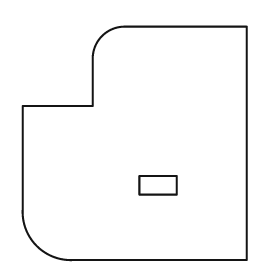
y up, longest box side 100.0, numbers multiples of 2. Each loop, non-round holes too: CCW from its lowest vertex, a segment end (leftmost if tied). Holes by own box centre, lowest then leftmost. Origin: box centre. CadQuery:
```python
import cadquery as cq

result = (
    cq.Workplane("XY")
    .moveTo(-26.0, -50.0)
    .lineTo(48.0, -50.0)
    .lineTo(48.0, 50.0)
    .lineTo(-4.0, 50.0)
    .threePointArc((-14.0, 46.0), (-18.0, 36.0))
    .lineTo(-18.0, 16.0)
    .lineTo(-48.0, 16.0)
    .lineTo(-48.0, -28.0)
    .threePointArc((-42.0, -44.0), (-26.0, -50.0))
    .close()
    .moveTo(2.0, -22.0)
    .lineTo(18.0, -22.0)
    .lineTo(18.0, -14.0)
    .lineTo(2.0, -14.0)
    .close()
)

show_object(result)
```